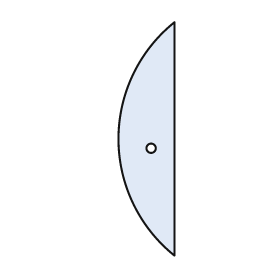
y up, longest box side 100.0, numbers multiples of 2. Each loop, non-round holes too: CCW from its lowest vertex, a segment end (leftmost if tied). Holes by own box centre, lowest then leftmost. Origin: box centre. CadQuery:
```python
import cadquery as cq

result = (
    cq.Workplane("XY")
    .moveTo(12.0, -50.0)
    .lineTo(12.0, 50.0)
    .threePointArc((-12.0, 0.0), (12.0, -50.0))
    .close()
    .moveTo(2.0, -4.0)
    .circle(2.0)
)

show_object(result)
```